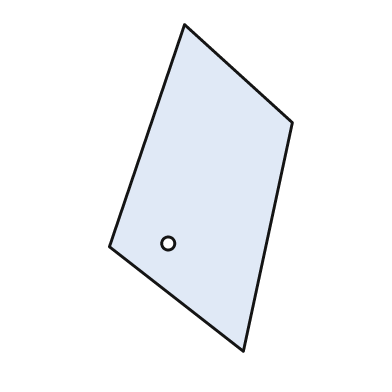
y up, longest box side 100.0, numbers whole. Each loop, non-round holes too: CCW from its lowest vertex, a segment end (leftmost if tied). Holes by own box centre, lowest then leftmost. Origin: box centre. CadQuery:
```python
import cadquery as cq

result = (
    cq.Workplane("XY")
    .moveTo(13.0, -50.0)
    .lineTo(28.0, 20.0)
    .lineTo(-5.0, 50.0)
    .lineTo(-28.0, -18.0)
    .close()
    .moveTo(-10.0, -17.0)
    .circle(2.0)
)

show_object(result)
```